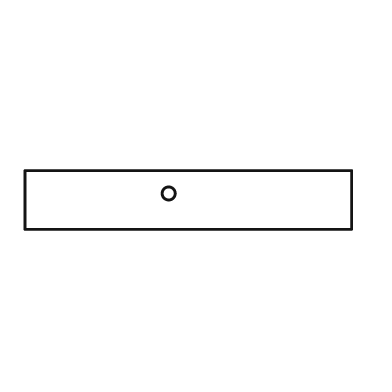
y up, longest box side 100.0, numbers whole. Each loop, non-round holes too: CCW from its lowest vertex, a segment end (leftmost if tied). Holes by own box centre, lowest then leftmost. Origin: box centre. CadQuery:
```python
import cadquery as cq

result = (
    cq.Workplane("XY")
    .moveTo(-50.0, -9.0)
    .lineTo(50.0, -9.0)
    .lineTo(50.0, 9.0)
    .lineTo(-50.0, 9.0)
    .close()
    .moveTo(-6.0, 2.0)
    .circle(2.0)
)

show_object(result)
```